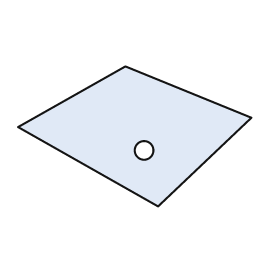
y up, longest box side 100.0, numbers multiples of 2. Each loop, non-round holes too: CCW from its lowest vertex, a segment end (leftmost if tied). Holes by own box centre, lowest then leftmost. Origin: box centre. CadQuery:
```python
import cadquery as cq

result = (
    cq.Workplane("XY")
    .moveTo(10.0, -30.0)
    .lineTo(50.0, 8.0)
    .lineTo(-4.0, 30.0)
    .lineTo(-50.0, 4.0)
    .close()
    .moveTo(4.0, -6.0)
    .circle(4.0)
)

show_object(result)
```